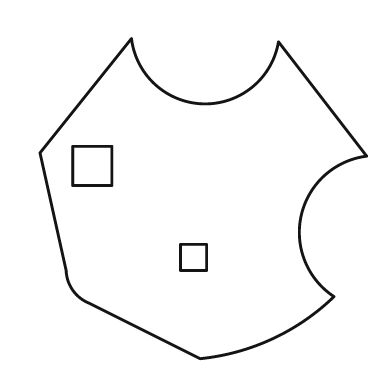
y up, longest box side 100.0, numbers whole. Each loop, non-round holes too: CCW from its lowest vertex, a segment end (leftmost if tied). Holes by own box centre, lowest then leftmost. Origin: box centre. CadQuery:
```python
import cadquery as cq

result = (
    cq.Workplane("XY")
    .moveTo(-1.0, -49.0)
    .threePointArc((21.0, -43.0), (40.0, -30.0))
    .threePointArc((30.0, -5.0), (50.0, 13.0))
    .lineTo(23.0, 48.0)
    .threePointArc((0.0, 29.0), (-22.0, 49.0))
    .lineTo(-50.0, 14.0)
    .lineTo(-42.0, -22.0)
    .threePointArc((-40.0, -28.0), (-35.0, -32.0))
    .close()
    .moveTo(-7.0, -22.0)
    .lineTo(1.0, -22.0)
    .lineTo(1.0, -14.0)
    .lineTo(-7.0, -14.0)
    .close()
    .moveTo(-40.0, 4.0)
    .lineTo(-28.0, 4.0)
    .lineTo(-28.0, 16.0)
    .lineTo(-40.0, 16.0)
    .close()
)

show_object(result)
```